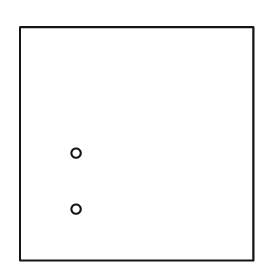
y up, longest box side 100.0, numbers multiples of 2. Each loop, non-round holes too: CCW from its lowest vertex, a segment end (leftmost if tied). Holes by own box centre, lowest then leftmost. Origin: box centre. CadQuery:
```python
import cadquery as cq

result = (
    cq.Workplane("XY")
    .moveTo(-50.0, -50.0)
    .lineTo(50.0, -50.0)
    .lineTo(50.0, 50.0)
    .lineTo(-50.0, 50.0)
    .close()
    .moveTo(-26.0, -28.0)
    .circle(2.0)
    .moveTo(-26.0, -4.0)
    .circle(2.0)
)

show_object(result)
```